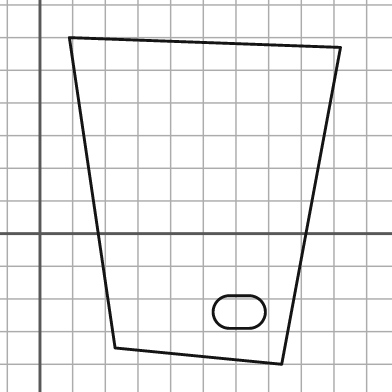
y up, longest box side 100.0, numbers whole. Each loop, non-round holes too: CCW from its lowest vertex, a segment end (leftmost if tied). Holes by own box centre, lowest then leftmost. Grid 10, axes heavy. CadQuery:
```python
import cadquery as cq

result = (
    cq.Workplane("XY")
    .moveTo(74.0, -40.0)
    .lineTo(92.0, 57.0)
    .lineTo(9.0, 60.0)
    .lineTo(23.0, -35.0)
    .close()
    .moveTo(58.0, -29.0)
    .lineTo(64.0, -29.0)
    .threePointArc((69.0, -24.0), (64.0, -19.0))
    .lineTo(58.0, -19.0)
    .threePointArc((53.0, -24.0), (58.0, -29.0))
    .close()
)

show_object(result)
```